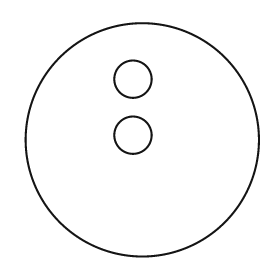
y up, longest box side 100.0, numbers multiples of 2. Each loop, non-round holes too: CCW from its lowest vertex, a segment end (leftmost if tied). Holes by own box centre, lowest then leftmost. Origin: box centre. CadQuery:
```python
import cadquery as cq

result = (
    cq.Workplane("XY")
    .moveTo(0.0, 0.0)
    .circle(50.0)
    .moveTo(-4.0, 2.0)
    .circle(8.0)
    .moveTo(-4.0, 26.0)
    .circle(8.0)
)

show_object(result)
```